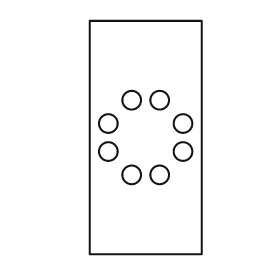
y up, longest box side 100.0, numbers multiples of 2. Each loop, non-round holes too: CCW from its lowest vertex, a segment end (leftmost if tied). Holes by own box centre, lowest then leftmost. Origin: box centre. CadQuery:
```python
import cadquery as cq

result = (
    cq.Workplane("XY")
    .moveTo(-24.0, -50.0)
    .lineTo(24.0, -50.0)
    .lineTo(24.0, 50.0)
    .lineTo(-24.0, 50.0)
    .close()
    .moveTo(-6.0, -16.0)
    .circle(4.0)
    .moveTo(6.0, -16.0)
    .circle(4.0)
    .moveTo(-16.0, -6.0)
    .circle(4.0)
    .moveTo(16.0, -6.0)
    .circle(4.0)
    .moveTo(-16.0, 6.0)
    .circle(4.0)
    .moveTo(16.0, 6.0)
    .circle(4.0)
    .moveTo(-6.0, 16.0)
    .circle(4.0)
    .moveTo(6.0, 16.0)
    .circle(4.0)
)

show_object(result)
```